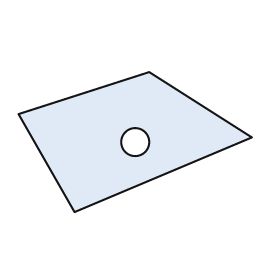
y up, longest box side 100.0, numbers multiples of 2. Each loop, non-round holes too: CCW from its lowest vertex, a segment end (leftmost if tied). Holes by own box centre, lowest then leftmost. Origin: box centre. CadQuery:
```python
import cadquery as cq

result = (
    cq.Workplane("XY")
    .moveTo(-26.0, -30.0)
    .lineTo(50.0, 2.0)
    .lineTo(6.0, 30.0)
    .lineTo(-50.0, 12.0)
    .close()
    .moveTo(0.0, 0.0)
    .circle(6.0)
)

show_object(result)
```